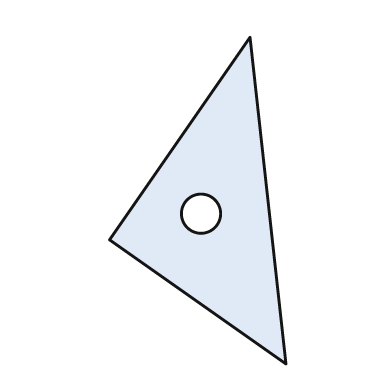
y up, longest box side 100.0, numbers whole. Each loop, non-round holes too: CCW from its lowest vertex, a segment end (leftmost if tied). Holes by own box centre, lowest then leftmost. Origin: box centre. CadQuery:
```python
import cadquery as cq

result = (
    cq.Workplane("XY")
    .moveTo(27.0, -50.0)
    .lineTo(16.0, 50.0)
    .lineTo(-27.0, -12.0)
    .close()
    .moveTo(1.0, -4.0)
    .circle(6.0)
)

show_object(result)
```